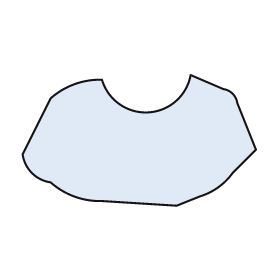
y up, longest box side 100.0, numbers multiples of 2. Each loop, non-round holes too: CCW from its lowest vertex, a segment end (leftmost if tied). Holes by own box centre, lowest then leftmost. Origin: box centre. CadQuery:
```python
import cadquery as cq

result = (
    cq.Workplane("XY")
    .moveTo(16.0, -28.0)
    .lineTo(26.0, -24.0)
    .threePointArc((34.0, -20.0), (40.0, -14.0))
    .lineTo(50.0, -4.0)
    .lineTo(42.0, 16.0)
    .threePointArc((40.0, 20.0), (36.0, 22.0))
    .lineTo(22.0, 28.0)
    .threePointArc((4.0, 12.0), (-16.0, 26.0))
    .threePointArc((-28.0, 24.0), (-38.0, 18.0))
    .lineTo(-50.0, -6.0)
    .threePointArc((-46.0, -14.0), (-38.0, -18.0))
    .threePointArc((-28.0, -24.0), (-16.0, -26.0))
    .close()
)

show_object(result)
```